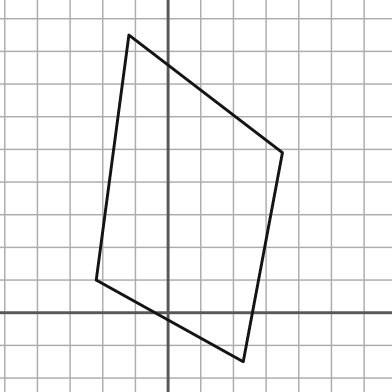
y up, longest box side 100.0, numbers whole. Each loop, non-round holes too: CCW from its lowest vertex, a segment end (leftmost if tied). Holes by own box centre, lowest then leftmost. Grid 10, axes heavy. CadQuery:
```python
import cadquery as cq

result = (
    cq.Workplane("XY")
    .moveTo(23.0, -15.0)
    .lineTo(35.0, 49.0)
    .lineTo(-12.0, 85.0)
    .lineTo(-22.0, 10.0)
    .close()
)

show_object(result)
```